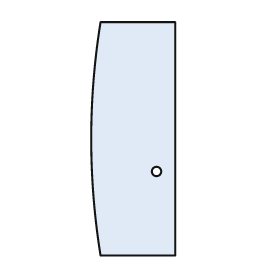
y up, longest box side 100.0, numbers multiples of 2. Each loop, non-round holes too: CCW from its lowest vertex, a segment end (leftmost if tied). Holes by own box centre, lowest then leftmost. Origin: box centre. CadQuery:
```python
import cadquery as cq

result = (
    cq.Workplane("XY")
    .moveTo(-14.0, -50.0)
    .lineTo(18.0, -50.0)
    .lineTo(18.0, 50.0)
    .lineTo(-14.0, 50.0)
    .threePointArc((-18.0, 0.0), (-14.0, -50.0))
    .close()
    .moveTo(10.0, -14.0)
    .circle(2.0)
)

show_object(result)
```